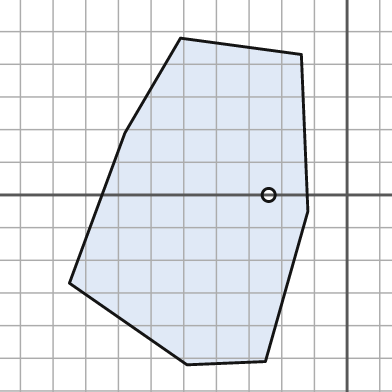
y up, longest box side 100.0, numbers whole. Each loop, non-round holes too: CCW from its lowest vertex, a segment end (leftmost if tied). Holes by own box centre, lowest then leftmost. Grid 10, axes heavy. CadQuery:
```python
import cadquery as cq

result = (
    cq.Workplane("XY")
    .moveTo(-49.0, -52.0)
    .lineTo(-25.0, -51.0)
    .lineTo(-12.0, -5.0)
    .lineTo(-14.0, 43.0)
    .lineTo(-51.0, 48.0)
    .lineTo(-68.0, 19.0)
    .lineTo(-85.0, -27.0)
    .close()
    .moveTo(-24.0, 0.0)
    .circle(2.0)
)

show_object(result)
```